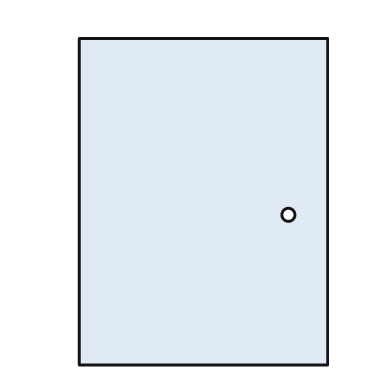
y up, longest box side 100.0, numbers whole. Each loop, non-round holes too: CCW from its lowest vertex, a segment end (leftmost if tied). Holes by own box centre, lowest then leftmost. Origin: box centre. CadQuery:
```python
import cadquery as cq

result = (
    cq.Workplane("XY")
    .moveTo(-38.0, -50.0)
    .lineTo(38.0, -50.0)
    .lineTo(38.0, 50.0)
    .lineTo(-38.0, 50.0)
    .close()
    .moveTo(26.0, -4.0)
    .circle(2.0)
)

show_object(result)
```